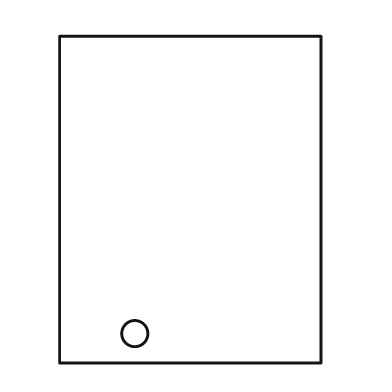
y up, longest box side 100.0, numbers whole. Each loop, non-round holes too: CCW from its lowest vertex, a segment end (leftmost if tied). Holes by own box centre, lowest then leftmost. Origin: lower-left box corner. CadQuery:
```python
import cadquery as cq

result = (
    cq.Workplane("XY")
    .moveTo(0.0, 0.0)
    .lineTo(80.0, 0.0)
    .lineTo(80.0, 100.0)
    .lineTo(0.0, 100.0)
    .close()
    .moveTo(23.0, 9.0)
    .circle(4.0)
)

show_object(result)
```